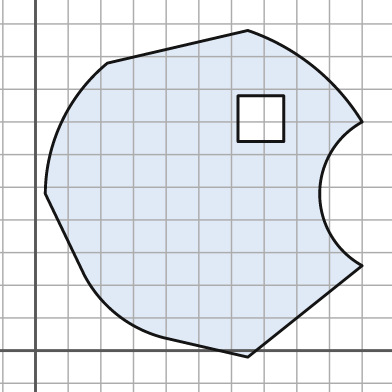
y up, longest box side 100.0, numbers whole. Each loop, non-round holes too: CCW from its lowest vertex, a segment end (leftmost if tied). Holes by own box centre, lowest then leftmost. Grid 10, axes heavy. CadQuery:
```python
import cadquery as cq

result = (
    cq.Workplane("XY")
    .moveTo(65.0, -2.0)
    .lineTo(100.0, 26.0)
    .threePointArc((87.0, 48.0), (100.0, 70.0))
    .threePointArc((85.0, 87.0), (65.0, 98.0))
    .lineTo(22.0, 88.0)
    .threePointArc((8.0, 70.0), (3.0, 48.0))
    .lineTo(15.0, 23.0)
    .threePointArc((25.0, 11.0), (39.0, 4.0))
    .close()
    .moveTo(62.0, 64.0)
    .lineTo(76.0, 64.0)
    .lineTo(76.0, 78.0)
    .lineTo(62.0, 78.0)
    .close()
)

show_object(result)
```